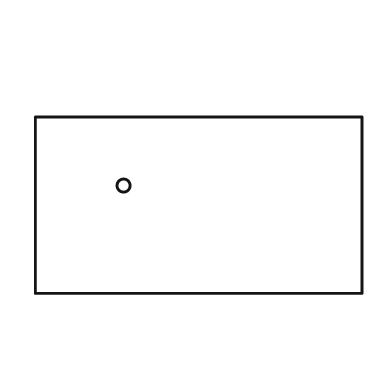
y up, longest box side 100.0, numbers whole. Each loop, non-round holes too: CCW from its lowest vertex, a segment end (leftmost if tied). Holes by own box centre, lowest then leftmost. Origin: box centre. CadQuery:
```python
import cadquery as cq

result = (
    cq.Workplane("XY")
    .moveTo(-50.0, -27.0)
    .lineTo(50.0, -27.0)
    .lineTo(50.0, 27.0)
    .lineTo(-50.0, 27.0)
    .close()
    .moveTo(-23.0, 6.0)
    .circle(2.0)
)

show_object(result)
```